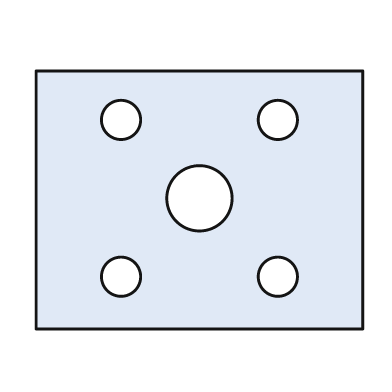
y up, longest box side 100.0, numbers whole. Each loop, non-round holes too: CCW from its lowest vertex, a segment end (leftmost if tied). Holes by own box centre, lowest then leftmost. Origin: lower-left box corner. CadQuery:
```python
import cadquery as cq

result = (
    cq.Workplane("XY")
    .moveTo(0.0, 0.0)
    .lineTo(100.0, 0.0)
    .lineTo(100.0, 79.0)
    .lineTo(0.0, 79.0)
    .close()
    .moveTo(26.0, 16.0)
    .circle(6.0)
    .moveTo(74.0, 16.0)
    .circle(6.0)
    .moveTo(50.0, 40.0)
    .circle(10.0)
    .moveTo(26.0, 64.0)
    .circle(6.0)
    .moveTo(74.0, 64.0)
    .circle(6.0)
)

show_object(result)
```